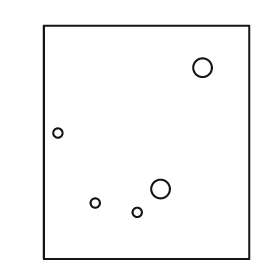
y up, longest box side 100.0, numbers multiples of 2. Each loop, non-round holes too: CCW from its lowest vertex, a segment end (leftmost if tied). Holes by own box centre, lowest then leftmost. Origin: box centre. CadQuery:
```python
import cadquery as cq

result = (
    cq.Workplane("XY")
    .moveTo(-44.0, -50.0)
    .lineTo(44.0, -50.0)
    .lineTo(44.0, 50.0)
    .lineTo(-44.0, 50.0)
    .close()
    .moveTo(-4.0, -30.0)
    .circle(2.0)
    .moveTo(-22.0, -26.0)
    .circle(2.0)
    .moveTo(6.0, -20.0)
    .circle(4.0)
    .moveTo(-38.0, 4.0)
    .circle(2.0)
    .moveTo(24.0, 32.0)
    .circle(4.0)
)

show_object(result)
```